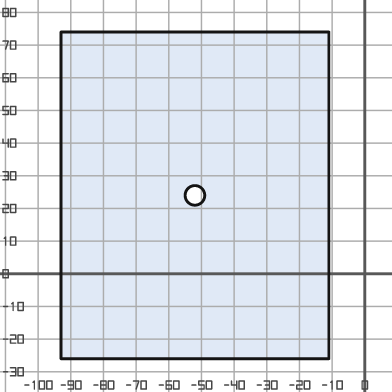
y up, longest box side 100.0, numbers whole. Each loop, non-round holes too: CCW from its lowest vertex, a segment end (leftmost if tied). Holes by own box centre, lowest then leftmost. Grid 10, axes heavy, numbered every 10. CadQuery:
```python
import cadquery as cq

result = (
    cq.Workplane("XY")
    .moveTo(-93.0, -26.0)
    .lineTo(-11.0, -26.0)
    .lineTo(-11.0, 74.0)
    .lineTo(-93.0, 74.0)
    .close()
    .moveTo(-52.0, 24.0)
    .circle(3.0)
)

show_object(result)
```